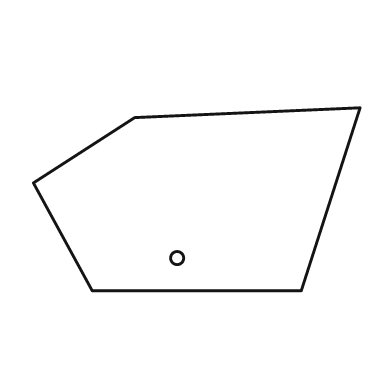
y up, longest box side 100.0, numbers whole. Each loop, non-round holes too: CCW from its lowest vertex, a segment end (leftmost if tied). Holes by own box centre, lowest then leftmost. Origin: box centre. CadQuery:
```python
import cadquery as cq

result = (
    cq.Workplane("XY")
    .moveTo(-32.0, -28.0)
    .lineTo(32.0, -28.0)
    .lineTo(50.0, 28.0)
    .lineTo(-19.0, 25.0)
    .lineTo(-50.0, 5.0)
    .close()
    .moveTo(-6.0, -18.0)
    .circle(2.0)
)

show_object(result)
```